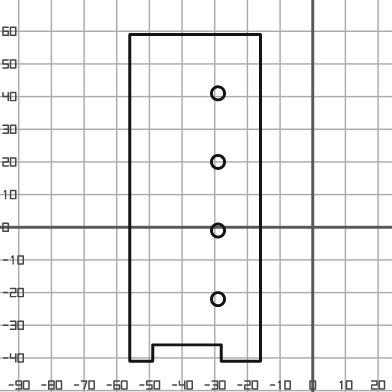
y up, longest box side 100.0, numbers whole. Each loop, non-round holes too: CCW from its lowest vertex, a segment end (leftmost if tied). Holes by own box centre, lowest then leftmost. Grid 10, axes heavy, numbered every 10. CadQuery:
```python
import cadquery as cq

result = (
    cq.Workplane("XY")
    .moveTo(-56.0, -41.0)
    .lineTo(-49.0, -41.0)
    .lineTo(-49.0, -36.0)
    .lineTo(-28.0, -36.0)
    .lineTo(-28.0, -41.0)
    .lineTo(-16.0, -41.0)
    .lineTo(-16.0, 59.0)
    .lineTo(-56.0, 59.0)
    .close()
    .moveTo(-29.0, -22.0)
    .circle(2.0)
    .moveTo(-29.0, -1.0)
    .circle(2.0)
    .moveTo(-29.0, 20.0)
    .circle(2.0)
    .moveTo(-29.0, 41.0)
    .circle(2.0)
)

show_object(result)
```